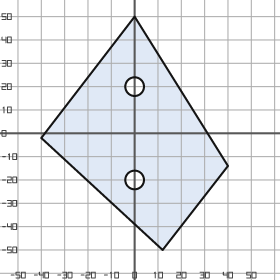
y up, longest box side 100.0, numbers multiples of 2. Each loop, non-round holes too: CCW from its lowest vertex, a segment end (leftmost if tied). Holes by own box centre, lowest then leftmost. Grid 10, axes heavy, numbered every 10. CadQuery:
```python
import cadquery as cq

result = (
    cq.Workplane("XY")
    .moveTo(12.0, -50.0)
    .lineTo(40.0, -14.0)
    .lineTo(0.0, 50.0)
    .lineTo(-40.0, -2.0)
    .close()
    .moveTo(0.0, -20.0)
    .circle(4.0)
    .moveTo(0.0, 20.0)
    .circle(4.0)
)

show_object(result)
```